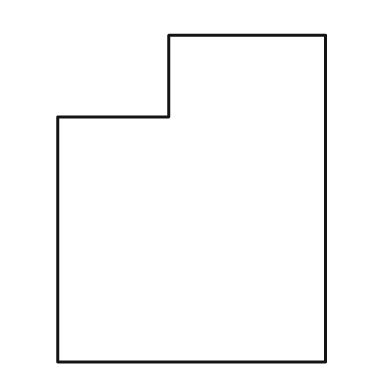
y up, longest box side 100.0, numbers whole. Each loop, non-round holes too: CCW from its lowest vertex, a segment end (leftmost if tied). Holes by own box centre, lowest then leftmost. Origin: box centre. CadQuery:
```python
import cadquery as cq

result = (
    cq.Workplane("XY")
    .moveTo(-41.0, -50.0)
    .lineTo(41.0, -50.0)
    .lineTo(41.0, 50.0)
    .lineTo(-7.0, 50.0)
    .lineTo(-7.0, 25.0)
    .lineTo(-41.0, 25.0)
    .close()
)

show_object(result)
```